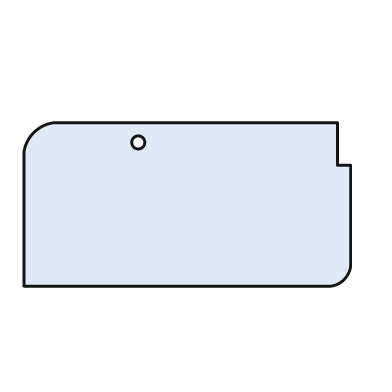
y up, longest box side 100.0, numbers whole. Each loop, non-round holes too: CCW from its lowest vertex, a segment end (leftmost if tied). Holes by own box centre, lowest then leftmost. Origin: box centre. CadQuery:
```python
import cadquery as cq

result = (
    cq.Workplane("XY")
    .moveTo(-50.0, -25.0)
    .lineTo(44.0, -25.0)
    .threePointArc((48.0, -23.0), (50.0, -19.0))
    .lineTo(50.0, 12.0)
    .lineTo(46.0, 12.0)
    .lineTo(46.0, 25.0)
    .lineTo(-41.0, 25.0)
    .threePointArc((-47.0, 22.0), (-50.0, 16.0))
    .close()
    .moveTo(-15.0, 19.0)
    .circle(2.0)
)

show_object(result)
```